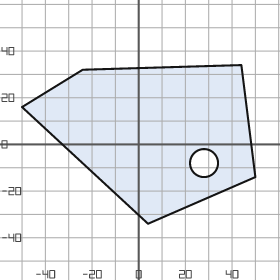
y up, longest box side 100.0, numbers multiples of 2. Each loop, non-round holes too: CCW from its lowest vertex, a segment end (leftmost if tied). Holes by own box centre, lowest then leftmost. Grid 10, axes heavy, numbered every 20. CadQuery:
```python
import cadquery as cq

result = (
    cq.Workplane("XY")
    .moveTo(4.0, -34.0)
    .lineTo(50.0, -14.0)
    .lineTo(44.0, 34.0)
    .lineTo(-24.0, 32.0)
    .lineTo(-50.0, 16.0)
    .close()
    .moveTo(28.0, -8.0)
    .circle(6.0)
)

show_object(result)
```